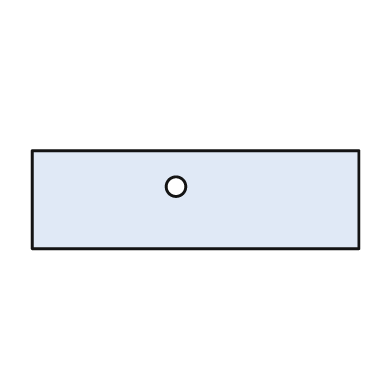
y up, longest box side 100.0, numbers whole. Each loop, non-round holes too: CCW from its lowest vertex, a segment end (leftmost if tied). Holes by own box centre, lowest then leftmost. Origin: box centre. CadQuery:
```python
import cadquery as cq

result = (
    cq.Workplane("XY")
    .moveTo(-50.0, -15.0)
    .lineTo(50.0, -15.0)
    .lineTo(50.0, 15.0)
    .lineTo(-50.0, 15.0)
    .close()
    .moveTo(-6.0, 4.0)
    .circle(3.0)
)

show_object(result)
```